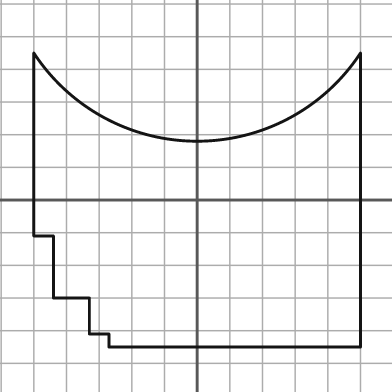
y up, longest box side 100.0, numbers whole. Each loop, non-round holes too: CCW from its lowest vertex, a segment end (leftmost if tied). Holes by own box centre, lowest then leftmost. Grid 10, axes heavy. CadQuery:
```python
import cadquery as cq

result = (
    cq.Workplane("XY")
    .moveTo(-27.0, -45.0)
    .lineTo(50.0, -45.0)
    .lineTo(50.0, 45.0)
    .threePointArc((0.0, 18.0), (-50.0, 45.0))
    .lineTo(-50.0, -11.0)
    .lineTo(-44.0, -11.0)
    .lineTo(-44.0, -30.0)
    .lineTo(-33.0, -30.0)
    .lineTo(-33.0, -41.0)
    .lineTo(-27.0, -41.0)
    .close()
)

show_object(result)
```